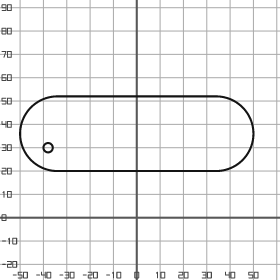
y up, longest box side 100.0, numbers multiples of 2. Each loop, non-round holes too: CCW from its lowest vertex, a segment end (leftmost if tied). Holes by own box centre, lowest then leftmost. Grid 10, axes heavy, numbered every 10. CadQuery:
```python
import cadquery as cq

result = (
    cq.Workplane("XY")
    .moveTo(-34.0, 20.0)
    .lineTo(34.0, 20.0)
    .threePointArc((50.0, 36.0), (34.0, 52.0))
    .lineTo(-34.0, 52.0)
    .threePointArc((-50.0, 36.0), (-34.0, 20.0))
    .close()
    .moveTo(-38.0, 30.0)
    .circle(2.0)
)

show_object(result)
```